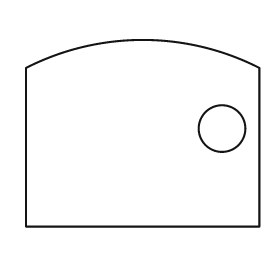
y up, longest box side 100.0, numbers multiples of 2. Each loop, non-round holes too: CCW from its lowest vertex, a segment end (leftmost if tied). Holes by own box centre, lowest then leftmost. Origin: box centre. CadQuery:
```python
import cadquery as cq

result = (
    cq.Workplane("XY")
    .moveTo(-50.0, -40.0)
    .lineTo(50.0, -40.0)
    .lineTo(50.0, 28.0)
    .threePointArc((0.0, 40.0), (-50.0, 28.0))
    .close()
    .moveTo(34.0, 2.0)
    .circle(10.0)
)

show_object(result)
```